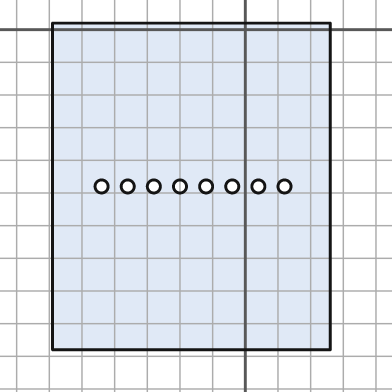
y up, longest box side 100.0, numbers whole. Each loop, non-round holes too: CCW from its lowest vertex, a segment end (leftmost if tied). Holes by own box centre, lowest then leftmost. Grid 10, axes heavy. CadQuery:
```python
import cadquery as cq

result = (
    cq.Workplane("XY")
    .moveTo(-59.0, -98.0)
    .lineTo(26.0, -98.0)
    .lineTo(26.0, 2.0)
    .lineTo(-59.0, 2.0)
    .close()
    .moveTo(-44.0, -48.0)
    .circle(2.0)
    .moveTo(-36.0, -48.0)
    .circle(2.0)
    .moveTo(-28.0, -48.0)
    .circle(2.0)
    .moveTo(-20.0, -48.0)
    .circle(2.0)
    .moveTo(-12.0, -48.0)
    .circle(2.0)
    .moveTo(-4.0, -48.0)
    .circle(2.0)
    .moveTo(4.0, -48.0)
    .circle(2.0)
    .moveTo(12.0, -48.0)
    .circle(2.0)
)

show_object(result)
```